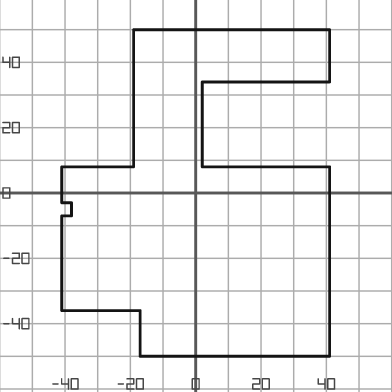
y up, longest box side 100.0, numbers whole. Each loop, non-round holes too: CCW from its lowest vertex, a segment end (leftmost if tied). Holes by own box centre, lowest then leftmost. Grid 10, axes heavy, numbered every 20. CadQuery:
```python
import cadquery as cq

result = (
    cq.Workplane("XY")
    .moveTo(-17.0, -50.0)
    .lineTo(41.0, -50.0)
    .lineTo(41.0, 8.0)
    .lineTo(2.0, 8.0)
    .lineTo(2.0, 34.0)
    .lineTo(41.0, 34.0)
    .lineTo(41.0, 50.0)
    .lineTo(-19.0, 50.0)
    .lineTo(-19.0, 8.0)
    .lineTo(-41.0, 8.0)
    .lineTo(-41.0, -3.0)
    .lineTo(-38.0, -3.0)
    .lineTo(-38.0, -7.0)
    .lineTo(-41.0, -7.0)
    .lineTo(-41.0, -36.0)
    .lineTo(-17.0, -36.0)
    .close()
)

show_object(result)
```